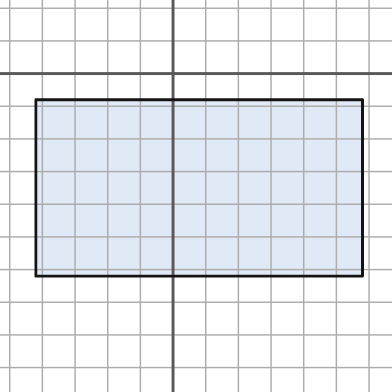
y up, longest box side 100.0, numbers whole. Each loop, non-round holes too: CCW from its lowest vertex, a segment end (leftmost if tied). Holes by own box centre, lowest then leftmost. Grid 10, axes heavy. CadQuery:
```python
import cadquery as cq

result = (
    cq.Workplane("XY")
    .moveTo(-42.0, -62.0)
    .lineTo(58.0, -62.0)
    .lineTo(58.0, -8.0)
    .lineTo(-42.0, -8.0)
    .close()
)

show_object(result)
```